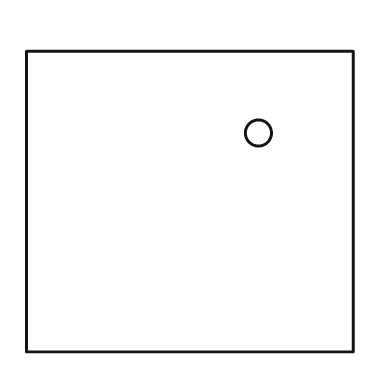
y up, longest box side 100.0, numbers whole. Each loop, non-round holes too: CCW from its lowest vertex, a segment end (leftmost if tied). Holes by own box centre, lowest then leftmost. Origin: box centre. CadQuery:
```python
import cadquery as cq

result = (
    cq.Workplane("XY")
    .moveTo(-50.0, -46.0)
    .lineTo(50.0, -46.0)
    .lineTo(50.0, 46.0)
    .lineTo(-50.0, 46.0)
    .close()
    .moveTo(21.0, 21.0)
    .circle(4.0)
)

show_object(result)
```